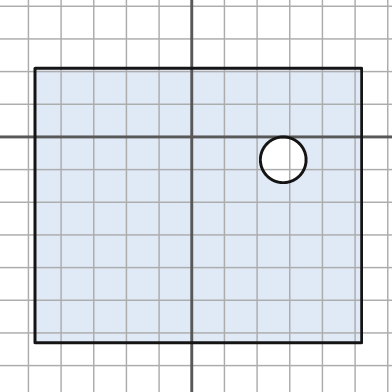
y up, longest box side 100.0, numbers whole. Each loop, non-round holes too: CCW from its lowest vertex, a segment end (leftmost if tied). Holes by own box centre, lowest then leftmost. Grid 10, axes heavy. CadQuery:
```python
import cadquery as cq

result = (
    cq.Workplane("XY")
    .moveTo(-48.0, -63.0)
    .lineTo(52.0, -63.0)
    .lineTo(52.0, 21.0)
    .lineTo(-48.0, 21.0)
    .close()
    .moveTo(28.0, -7.0)
    .circle(7.0)
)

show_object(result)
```